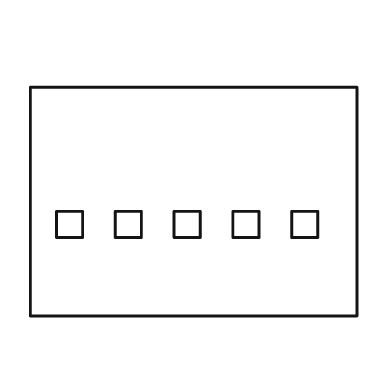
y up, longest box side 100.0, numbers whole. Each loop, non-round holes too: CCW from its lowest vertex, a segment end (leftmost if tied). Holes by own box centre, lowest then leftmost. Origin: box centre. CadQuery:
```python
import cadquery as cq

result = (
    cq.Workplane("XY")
    .moveTo(-50.0, -35.0)
    .lineTo(50.0, -35.0)
    .lineTo(50.0, 35.0)
    .lineTo(-50.0, 35.0)
    .close()
    .moveTo(-42.0, -11.0)
    .lineTo(-34.0, -11.0)
    .lineTo(-34.0, -3.0)
    .lineTo(-42.0, -3.0)
    .close()
    .moveTo(-24.0, -11.0)
    .lineTo(-16.0, -11.0)
    .lineTo(-16.0, -3.0)
    .lineTo(-24.0, -3.0)
    .close()
    .moveTo(-6.0, -11.0)
    .lineTo(2.0, -11.0)
    .lineTo(2.0, -3.0)
    .lineTo(-6.0, -3.0)
    .close()
    .moveTo(12.0, -11.0)
    .lineTo(20.0, -11.0)
    .lineTo(20.0, -3.0)
    .lineTo(12.0, -3.0)
    .close()
    .moveTo(30.0, -11.0)
    .lineTo(38.0, -11.0)
    .lineTo(38.0, -3.0)
    .lineTo(30.0, -3.0)
    .close()
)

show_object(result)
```